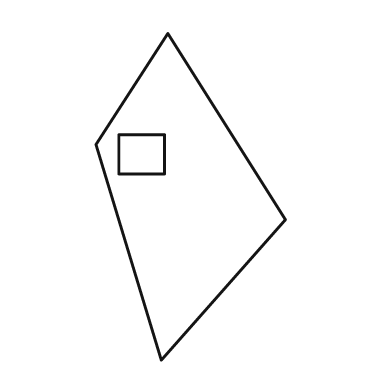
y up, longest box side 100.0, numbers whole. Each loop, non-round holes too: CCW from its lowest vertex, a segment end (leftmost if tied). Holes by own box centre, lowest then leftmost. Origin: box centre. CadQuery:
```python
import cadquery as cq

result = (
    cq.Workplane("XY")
    .moveTo(-9.0, -50.0)
    .lineTo(29.0, -7.0)
    .lineTo(-7.0, 50.0)
    .lineTo(-29.0, 16.0)
    .close()
    .moveTo(-22.0, 7.0)
    .lineTo(-8.0, 7.0)
    .lineTo(-8.0, 19.0)
    .lineTo(-22.0, 19.0)
    .close()
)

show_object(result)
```